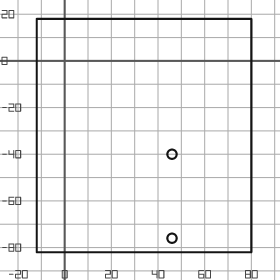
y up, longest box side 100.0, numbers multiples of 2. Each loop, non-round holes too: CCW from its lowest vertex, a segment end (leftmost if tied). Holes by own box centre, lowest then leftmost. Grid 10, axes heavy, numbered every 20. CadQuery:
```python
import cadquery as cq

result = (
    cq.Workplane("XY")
    .moveTo(-12.0, -82.0)
    .lineTo(80.0, -82.0)
    .lineTo(80.0, 18.0)
    .lineTo(-12.0, 18.0)
    .close()
    .moveTo(46.0, -76.0)
    .circle(2.0)
    .moveTo(46.0, -40.0)
    .circle(2.0)
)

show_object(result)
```